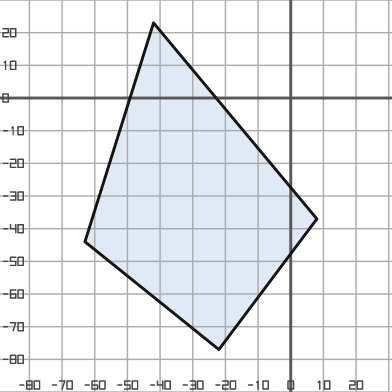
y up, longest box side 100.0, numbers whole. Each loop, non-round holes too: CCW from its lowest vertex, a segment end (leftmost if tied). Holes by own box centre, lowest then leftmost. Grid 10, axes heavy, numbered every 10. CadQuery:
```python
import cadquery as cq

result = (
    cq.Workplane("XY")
    .moveTo(-22.0, -77.0)
    .lineTo(8.0, -37.0)
    .lineTo(-42.0, 23.0)
    .lineTo(-63.0, -44.0)
    .close()
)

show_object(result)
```